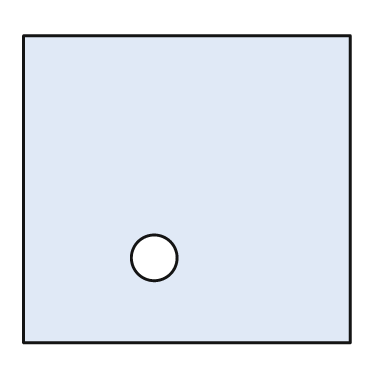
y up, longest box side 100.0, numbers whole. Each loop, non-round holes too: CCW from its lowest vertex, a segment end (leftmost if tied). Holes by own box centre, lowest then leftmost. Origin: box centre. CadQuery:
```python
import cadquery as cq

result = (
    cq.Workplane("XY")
    .moveTo(-50.0, -47.0)
    .lineTo(50.0, -47.0)
    .lineTo(50.0, 47.0)
    .lineTo(-50.0, 47.0)
    .close()
    .moveTo(-10.0, -21.0)
    .circle(7.0)
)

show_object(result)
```